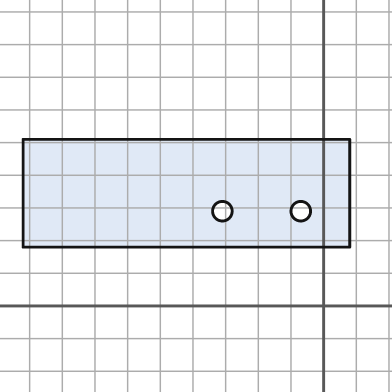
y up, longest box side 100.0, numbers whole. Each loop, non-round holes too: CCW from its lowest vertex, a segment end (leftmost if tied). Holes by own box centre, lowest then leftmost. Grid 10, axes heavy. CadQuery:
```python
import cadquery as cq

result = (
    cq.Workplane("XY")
    .moveTo(-92.0, 18.0)
    .lineTo(8.0, 18.0)
    .lineTo(8.0, 51.0)
    .lineTo(-92.0, 51.0)
    .close()
    .moveTo(-31.0, 29.0)
    .circle(3.0)
    .moveTo(-7.0, 29.0)
    .circle(3.0)
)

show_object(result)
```